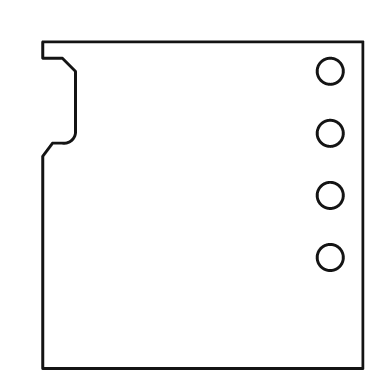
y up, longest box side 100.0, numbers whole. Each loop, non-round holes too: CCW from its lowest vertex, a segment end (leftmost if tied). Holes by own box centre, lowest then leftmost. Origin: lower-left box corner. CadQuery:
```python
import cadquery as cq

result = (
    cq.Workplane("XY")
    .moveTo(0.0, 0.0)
    .lineTo(98.0, 0.0)
    .lineTo(98.0, 100.0)
    .lineTo(0.0, 100.0)
    .lineTo(0.0, 95.0)
    .lineTo(6.0, 95.0)
    .lineTo(10.0, 91.0)
    .lineTo(10.0, 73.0)
    .threePointArc((9.0, 70.0), (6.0, 69.0))
    .lineTo(3.0, 69.0)
    .lineTo(0.0, 65.0)
    .close()
    .moveTo(88.0, 34.0)
    .circle(4.0)
    .moveTo(88.0, 53.0)
    .circle(4.0)
    .moveTo(88.0, 72.0)
    .circle(4.0)
    .moveTo(88.0, 91.0)
    .circle(4.0)
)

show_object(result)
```